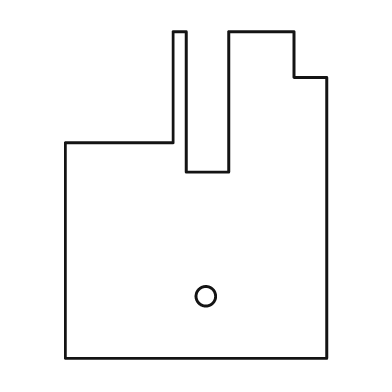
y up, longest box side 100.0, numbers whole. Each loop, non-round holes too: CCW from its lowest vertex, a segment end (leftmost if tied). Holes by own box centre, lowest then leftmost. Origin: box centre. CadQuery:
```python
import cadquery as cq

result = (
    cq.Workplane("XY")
    .moveTo(-40.0, -50.0)
    .lineTo(40.0, -50.0)
    .lineTo(40.0, 36.0)
    .lineTo(30.0, 36.0)
    .lineTo(30.0, 50.0)
    .lineTo(10.0, 50.0)
    .lineTo(10.0, 7.0)
    .lineTo(-3.0, 7.0)
    .lineTo(-3.0, 50.0)
    .lineTo(-7.0, 50.0)
    .lineTo(-7.0, 16.0)
    .lineTo(-40.0, 16.0)
    .close()
    .moveTo(3.0, -31.0)
    .circle(3.0)
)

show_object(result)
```